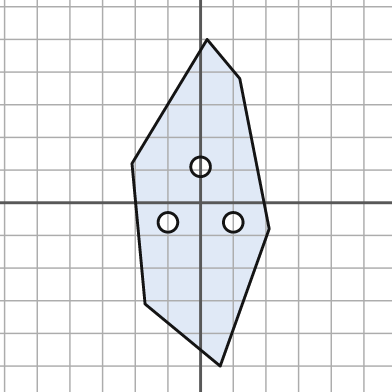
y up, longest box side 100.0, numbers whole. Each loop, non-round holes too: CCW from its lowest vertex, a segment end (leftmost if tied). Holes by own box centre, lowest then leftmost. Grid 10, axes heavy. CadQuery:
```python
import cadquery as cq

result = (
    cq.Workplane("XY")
    .moveTo(6.0, -50.0)
    .lineTo(21.0, -8.0)
    .lineTo(12.0, 38.0)
    .lineTo(2.0, 50.0)
    .lineTo(-21.0, 12.0)
    .lineTo(-17.0, -31.0)
    .close()
    .moveTo(-10.0, -6.0)
    .circle(3.0)
    .moveTo(10.0, -6.0)
    .circle(3.0)
    .moveTo(0.0, 11.0)
    .circle(3.0)
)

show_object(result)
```